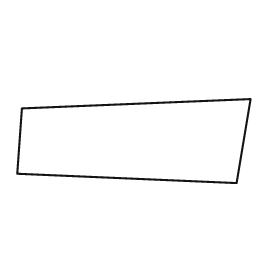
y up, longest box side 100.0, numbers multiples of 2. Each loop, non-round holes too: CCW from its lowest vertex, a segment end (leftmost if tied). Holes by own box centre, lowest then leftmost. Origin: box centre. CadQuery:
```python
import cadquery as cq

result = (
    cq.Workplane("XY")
    .moveTo(44.0, -18.0)
    .lineTo(50.0, 18.0)
    .lineTo(-48.0, 14.0)
    .lineTo(-50.0, -14.0)
    .close()
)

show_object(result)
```